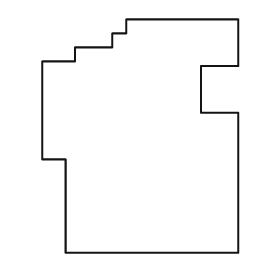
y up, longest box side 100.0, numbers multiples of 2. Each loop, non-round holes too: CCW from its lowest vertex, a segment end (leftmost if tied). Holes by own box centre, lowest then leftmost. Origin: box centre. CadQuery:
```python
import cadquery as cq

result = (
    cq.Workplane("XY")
    .moveTo(-32.0, -50.0)
    .lineTo(42.0, -50.0)
    .lineTo(42.0, 10.0)
    .lineTo(26.0, 10.0)
    .lineTo(26.0, 30.0)
    .lineTo(42.0, 30.0)
    .lineTo(42.0, 50.0)
    .lineTo(-6.0, 50.0)
    .lineTo(-6.0, 44.0)
    .lineTo(-12.0, 44.0)
    .lineTo(-12.0, 38.0)
    .lineTo(-28.0, 38.0)
    .lineTo(-28.0, 32.0)
    .lineTo(-42.0, 32.0)
    .lineTo(-42.0, -10.0)
    .lineTo(-32.0, -10.0)
    .close()
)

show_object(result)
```